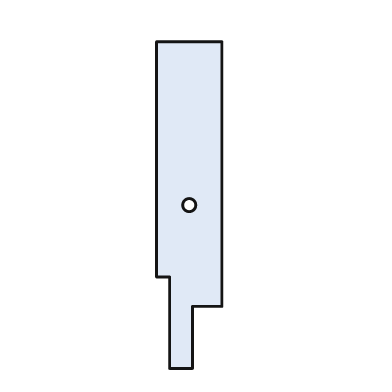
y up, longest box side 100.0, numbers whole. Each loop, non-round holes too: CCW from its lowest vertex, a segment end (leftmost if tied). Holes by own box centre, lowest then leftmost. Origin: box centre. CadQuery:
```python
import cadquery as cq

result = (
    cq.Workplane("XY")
    .moveTo(-6.0, -50.0)
    .lineTo(1.0, -50.0)
    .lineTo(1.0, -31.0)
    .lineTo(10.0, -31.0)
    .lineTo(10.0, 50.0)
    .lineTo(-10.0, 50.0)
    .lineTo(-10.0, -22.0)
    .lineTo(-6.0, -22.0)
    .close()
    .moveTo(0.0, 0.0)
    .circle(2.0)
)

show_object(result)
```